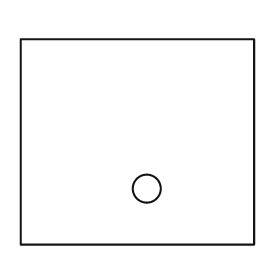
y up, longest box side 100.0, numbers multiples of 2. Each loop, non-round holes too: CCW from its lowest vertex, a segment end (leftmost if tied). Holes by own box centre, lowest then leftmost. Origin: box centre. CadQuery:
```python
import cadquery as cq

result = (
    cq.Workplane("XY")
    .moveTo(-50.0, -44.0)
    .lineTo(50.0, -44.0)
    .lineTo(50.0, 44.0)
    .lineTo(-50.0, 44.0)
    .close()
    .moveTo(4.0, -20.0)
    .circle(6.0)
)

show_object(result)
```